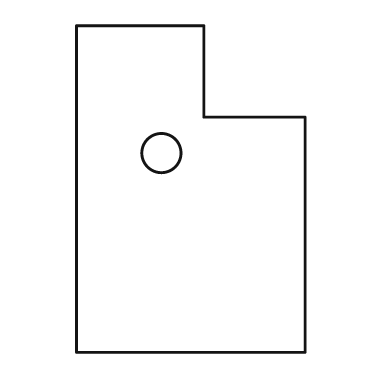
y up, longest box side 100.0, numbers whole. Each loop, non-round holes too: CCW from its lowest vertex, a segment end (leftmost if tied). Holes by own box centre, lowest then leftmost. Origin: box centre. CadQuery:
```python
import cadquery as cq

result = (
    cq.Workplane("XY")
    .moveTo(-35.0, -50.0)
    .lineTo(35.0, -50.0)
    .lineTo(35.0, 22.0)
    .lineTo(4.0, 22.0)
    .lineTo(4.0, 50.0)
    .lineTo(-35.0, 50.0)
    .close()
    .moveTo(-9.0, 11.0)
    .circle(6.0)
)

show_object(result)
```